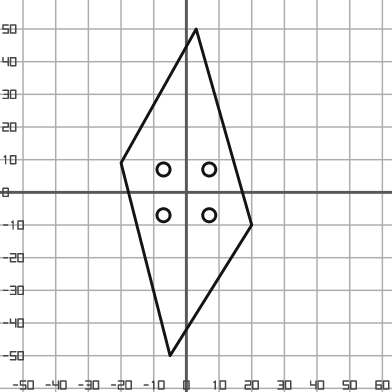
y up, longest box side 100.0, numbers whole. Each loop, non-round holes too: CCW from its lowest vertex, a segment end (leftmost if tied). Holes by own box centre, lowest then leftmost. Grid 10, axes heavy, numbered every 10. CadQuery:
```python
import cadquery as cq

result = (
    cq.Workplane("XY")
    .moveTo(-5.0, -50.0)
    .lineTo(20.0, -10.0)
    .lineTo(3.0, 50.0)
    .lineTo(-20.0, 9.0)
    .close()
    .moveTo(-7.0, -7.0)
    .circle(2.0)
    .moveTo(7.0, -7.0)
    .circle(2.0)
    .moveTo(-7.0, 7.0)
    .circle(2.0)
    .moveTo(7.0, 7.0)
    .circle(2.0)
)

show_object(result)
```